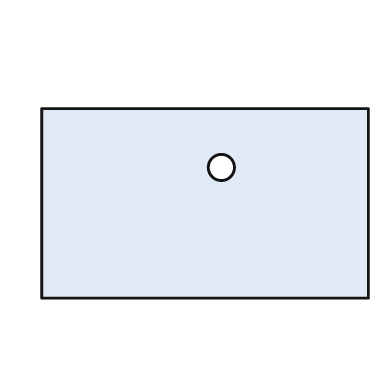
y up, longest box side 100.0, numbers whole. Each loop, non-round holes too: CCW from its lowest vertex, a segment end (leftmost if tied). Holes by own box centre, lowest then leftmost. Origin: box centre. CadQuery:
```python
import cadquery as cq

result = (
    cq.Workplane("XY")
    .moveTo(-50.0, -29.0)
    .lineTo(50.0, -29.0)
    .lineTo(50.0, 29.0)
    .lineTo(-50.0, 29.0)
    .close()
    .moveTo(5.0, 11.0)
    .circle(4.0)
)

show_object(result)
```